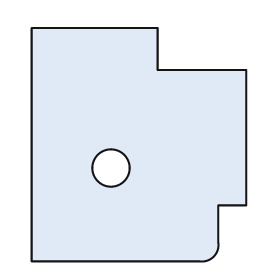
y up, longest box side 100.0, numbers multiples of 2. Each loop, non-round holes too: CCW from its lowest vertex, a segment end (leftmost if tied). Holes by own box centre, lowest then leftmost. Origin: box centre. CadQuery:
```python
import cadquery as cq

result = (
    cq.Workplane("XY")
    .moveTo(-46.0, -50.0)
    .lineTo(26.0, -50.0)
    .threePointArc((32.0, -48.0), (34.0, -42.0))
    .lineTo(34.0, -26.0)
    .lineTo(46.0, -26.0)
    .lineTo(46.0, 32.0)
    .lineTo(8.0, 32.0)
    .lineTo(8.0, 50.0)
    .lineTo(-46.0, 50.0)
    .close()
    .moveTo(-12.0, -10.0)
    .circle(8.0)
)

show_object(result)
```